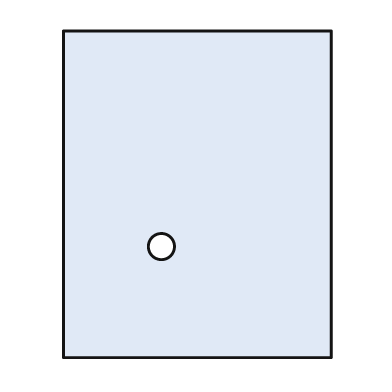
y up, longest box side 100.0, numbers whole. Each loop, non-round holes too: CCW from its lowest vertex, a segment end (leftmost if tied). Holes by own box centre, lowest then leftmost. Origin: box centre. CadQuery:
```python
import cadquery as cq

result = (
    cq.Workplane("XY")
    .moveTo(-41.0, -50.0)
    .lineTo(41.0, -50.0)
    .lineTo(41.0, 50.0)
    .lineTo(-41.0, 50.0)
    .close()
    .moveTo(-11.0, -16.0)
    .circle(4.0)
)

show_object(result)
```